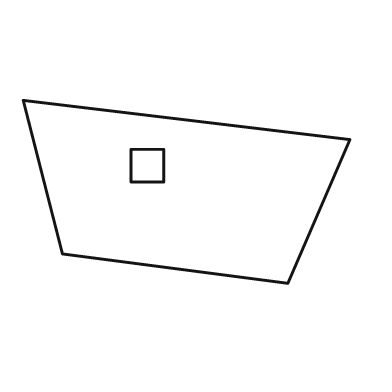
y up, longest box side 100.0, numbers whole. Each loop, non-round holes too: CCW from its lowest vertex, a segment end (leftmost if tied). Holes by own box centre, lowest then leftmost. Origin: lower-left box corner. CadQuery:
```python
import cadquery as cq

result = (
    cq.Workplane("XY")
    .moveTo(81.0, 0.0)
    .lineTo(100.0, 44.0)
    .lineTo(0.0, 56.0)
    .lineTo(12.0, 9.0)
    .close()
    .moveTo(33.0, 31.0)
    .lineTo(43.0, 31.0)
    .lineTo(43.0, 41.0)
    .lineTo(33.0, 41.0)
    .close()
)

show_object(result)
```